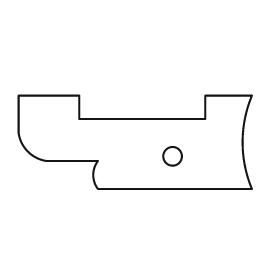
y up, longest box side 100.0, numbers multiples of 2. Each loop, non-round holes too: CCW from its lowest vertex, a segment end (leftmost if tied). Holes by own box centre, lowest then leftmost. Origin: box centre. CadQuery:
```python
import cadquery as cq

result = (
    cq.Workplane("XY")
    .moveTo(-16.0, -20.0)
    .lineTo(50.0, -20.0)
    .threePointArc((46.0, 0.0), (50.0, 20.0))
    .lineTo(30.0, 20.0)
    .lineTo(30.0, 10.0)
    .lineTo(-24.0, 10.0)
    .lineTo(-24.0, 20.0)
    .lineTo(-50.0, 20.0)
    .lineTo(-50.0, 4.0)
    .threePointArc((-46.0, -4.0), (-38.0, -8.0))
    .lineTo(-16.0, -8.0)
    .threePointArc((-18.0, -14.0), (-16.0, -20.0))
    .close()
    .moveTo(16.0, -6.0)
    .circle(4.0)
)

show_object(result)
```